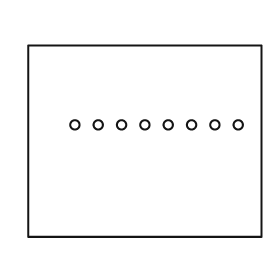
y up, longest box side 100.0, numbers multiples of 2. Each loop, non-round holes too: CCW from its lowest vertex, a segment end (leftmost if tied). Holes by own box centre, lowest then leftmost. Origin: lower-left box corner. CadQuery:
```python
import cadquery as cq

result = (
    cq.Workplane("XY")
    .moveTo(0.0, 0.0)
    .lineTo(100.0, 0.0)
    .lineTo(100.0, 82.0)
    .lineTo(0.0, 82.0)
    .close()
    .moveTo(20.0, 48.0)
    .circle(2.0)
    .moveTo(30.0, 48.0)
    .circle(2.0)
    .moveTo(40.0, 48.0)
    .circle(2.0)
    .moveTo(50.0, 48.0)
    .circle(2.0)
    .moveTo(60.0, 48.0)
    .circle(2.0)
    .moveTo(70.0, 48.0)
    .circle(2.0)
    .moveTo(80.0, 48.0)
    .circle(2.0)
    .moveTo(90.0, 48.0)
    .circle(2.0)
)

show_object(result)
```